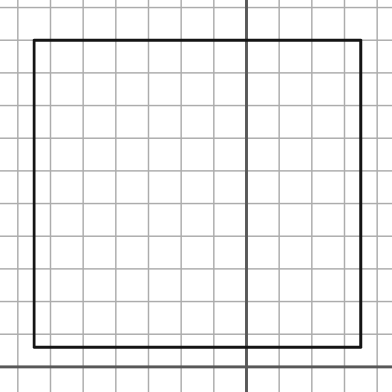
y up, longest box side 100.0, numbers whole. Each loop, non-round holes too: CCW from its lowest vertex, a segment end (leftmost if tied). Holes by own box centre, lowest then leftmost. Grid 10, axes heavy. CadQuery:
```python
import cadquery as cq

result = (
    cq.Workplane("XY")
    .moveTo(-65.0, 6.0)
    .lineTo(35.0, 6.0)
    .lineTo(35.0, 100.0)
    .lineTo(-65.0, 100.0)
    .close()
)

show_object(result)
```